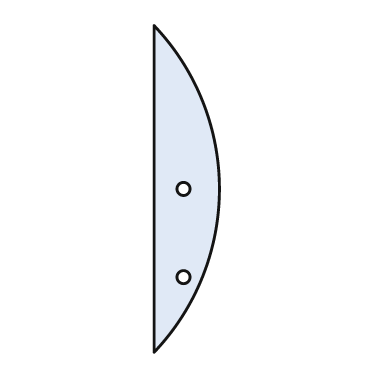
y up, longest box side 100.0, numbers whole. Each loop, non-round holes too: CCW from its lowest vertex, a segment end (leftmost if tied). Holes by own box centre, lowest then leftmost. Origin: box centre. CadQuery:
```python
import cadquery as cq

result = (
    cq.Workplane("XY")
    .moveTo(-10.0, -50.0)
    .threePointArc((10.0, 0.0), (-10.0, 50.0))
    .close()
    .moveTo(-1.0, -27.0)
    .circle(2.0)
    .moveTo(-1.0, 0.0)
    .circle(2.0)
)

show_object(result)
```